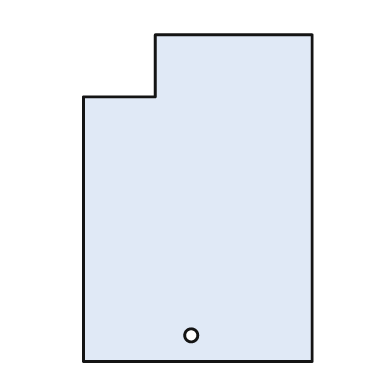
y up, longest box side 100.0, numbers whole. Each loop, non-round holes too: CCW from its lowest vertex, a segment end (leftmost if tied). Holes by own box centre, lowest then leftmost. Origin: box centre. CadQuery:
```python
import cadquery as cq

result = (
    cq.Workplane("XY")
    .moveTo(-35.0, -50.0)
    .lineTo(35.0, -50.0)
    .lineTo(35.0, 50.0)
    .lineTo(-13.0, 50.0)
    .lineTo(-13.0, 31.0)
    .lineTo(-35.0, 31.0)
    .close()
    .moveTo(-2.0, -42.0)
    .circle(2.0)
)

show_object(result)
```